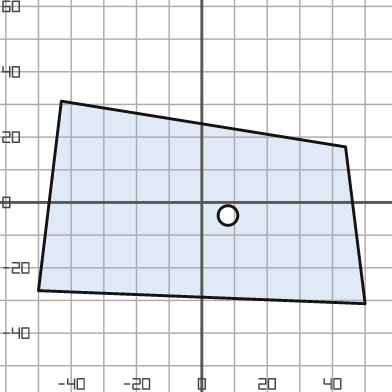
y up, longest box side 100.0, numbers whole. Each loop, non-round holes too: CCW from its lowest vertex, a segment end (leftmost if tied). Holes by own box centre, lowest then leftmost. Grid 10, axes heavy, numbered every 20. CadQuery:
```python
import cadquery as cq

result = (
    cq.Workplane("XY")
    .moveTo(50.0, -31.0)
    .lineTo(44.0, 17.0)
    .lineTo(-43.0, 31.0)
    .lineTo(-50.0, -27.0)
    .close()
    .moveTo(8.0, -4.0)
    .circle(3.0)
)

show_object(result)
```